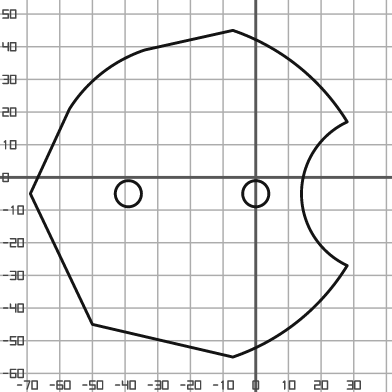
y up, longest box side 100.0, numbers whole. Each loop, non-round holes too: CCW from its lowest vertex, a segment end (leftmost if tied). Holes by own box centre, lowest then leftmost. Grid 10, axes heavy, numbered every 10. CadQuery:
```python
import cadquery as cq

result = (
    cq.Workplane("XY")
    .moveTo(-7.0, -55.0)
    .threePointArc((13.0, -44.0), (28.0, -27.0))
    .threePointArc((14.0, -5.0), (28.0, 17.0))
    .threePointArc((13.0, 34.0), (-7.0, 45.0))
    .lineTo(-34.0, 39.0)
    .threePointArc((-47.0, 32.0), (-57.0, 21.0))
    .lineTo(-69.0, -5.0)
    .lineTo(-50.0, -45.0)
    .close()
    .moveTo(-39.0, -5.0)
    .circle(4.0)
    .moveTo(0.0, -5.0)
    .circle(4.0)
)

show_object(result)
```